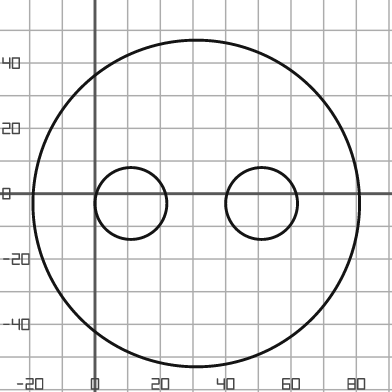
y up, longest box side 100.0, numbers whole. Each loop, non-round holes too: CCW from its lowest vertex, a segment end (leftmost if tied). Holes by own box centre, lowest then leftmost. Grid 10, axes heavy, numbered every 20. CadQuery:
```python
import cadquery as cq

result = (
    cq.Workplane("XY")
    .moveTo(31.0, -3.0)
    .circle(50.0)
    .moveTo(11.0, -3.0)
    .circle(11.0)
    .moveTo(51.0, -3.0)
    .circle(11.0)
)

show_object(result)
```